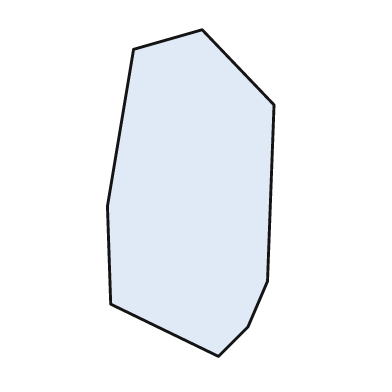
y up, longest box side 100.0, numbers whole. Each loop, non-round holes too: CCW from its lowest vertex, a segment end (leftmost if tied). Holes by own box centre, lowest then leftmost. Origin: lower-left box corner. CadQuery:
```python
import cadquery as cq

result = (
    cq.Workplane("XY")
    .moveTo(34.0, 0.0)
    .lineTo(43.0, 9.0)
    .lineTo(49.0, 23.0)
    .lineTo(51.0, 77.0)
    .lineTo(29.0, 100.0)
    .lineTo(8.0, 94.0)
    .lineTo(0.0, 46.0)
    .lineTo(1.0, 16.0)
    .close()
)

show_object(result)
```